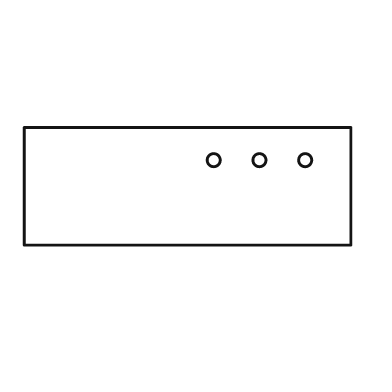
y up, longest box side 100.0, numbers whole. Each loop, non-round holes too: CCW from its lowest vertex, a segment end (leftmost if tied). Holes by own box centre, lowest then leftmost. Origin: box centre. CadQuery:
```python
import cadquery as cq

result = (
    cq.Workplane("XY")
    .moveTo(-50.0, -18.0)
    .lineTo(50.0, -18.0)
    .lineTo(50.0, 18.0)
    .lineTo(-50.0, 18.0)
    .close()
    .moveTo(8.0, 8.0)
    .circle(2.0)
    .moveTo(22.0, 8.0)
    .circle(2.0)
    .moveTo(36.0, 8.0)
    .circle(2.0)
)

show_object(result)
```